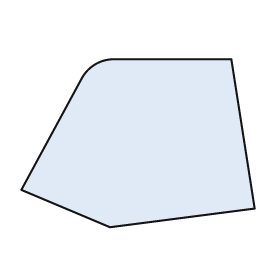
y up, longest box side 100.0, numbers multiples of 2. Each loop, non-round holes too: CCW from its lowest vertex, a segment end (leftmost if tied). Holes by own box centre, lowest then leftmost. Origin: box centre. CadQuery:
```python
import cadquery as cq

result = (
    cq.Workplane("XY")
    .moveTo(-12.0, -36.0)
    .lineTo(50.0, -28.0)
    .lineTo(40.0, 36.0)
    .lineTo(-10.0, 36.0)
    .threePointArc((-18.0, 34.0), (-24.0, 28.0))
    .lineTo(-50.0, -20.0)
    .close()
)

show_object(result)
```